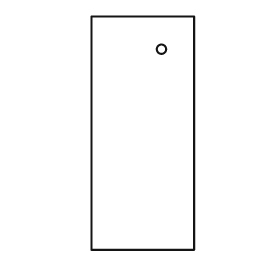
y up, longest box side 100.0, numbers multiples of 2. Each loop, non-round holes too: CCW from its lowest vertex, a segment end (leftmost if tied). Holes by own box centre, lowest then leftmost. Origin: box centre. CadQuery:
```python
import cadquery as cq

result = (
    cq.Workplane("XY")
    .moveTo(-22.0, -50.0)
    .lineTo(22.0, -50.0)
    .lineTo(22.0, 50.0)
    .lineTo(-22.0, 50.0)
    .close()
    .moveTo(8.0, 36.0)
    .circle(2.0)
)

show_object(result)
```